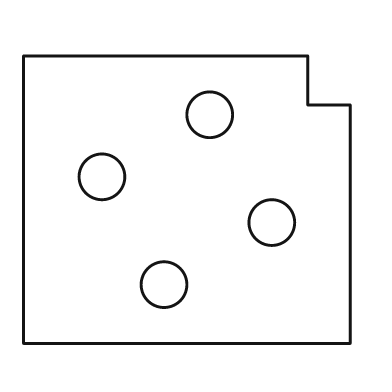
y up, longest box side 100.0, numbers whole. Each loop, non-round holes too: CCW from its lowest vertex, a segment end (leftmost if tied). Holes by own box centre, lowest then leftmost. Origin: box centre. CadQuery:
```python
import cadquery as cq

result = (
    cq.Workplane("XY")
    .moveTo(-50.0, -44.0)
    .lineTo(50.0, -44.0)
    .lineTo(50.0, 29.0)
    .lineTo(37.0, 29.0)
    .lineTo(37.0, 44.0)
    .lineTo(-50.0, 44.0)
    .close()
    .moveTo(-7.0, -26.0)
    .circle(7.0)
    .moveTo(26.0, -7.0)
    .circle(7.0)
    .moveTo(-26.0, 7.0)
    .circle(7.0)
    .moveTo(7.0, 26.0)
    .circle(7.0)
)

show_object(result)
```